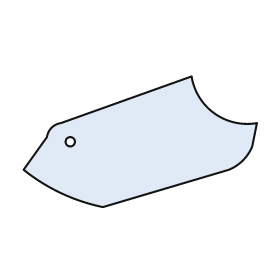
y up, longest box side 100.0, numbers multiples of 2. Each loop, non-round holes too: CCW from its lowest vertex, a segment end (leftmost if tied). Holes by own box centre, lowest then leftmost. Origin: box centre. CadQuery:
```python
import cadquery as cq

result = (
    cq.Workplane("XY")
    .moveTo(-16.0, -28.0)
    .lineTo(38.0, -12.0)
    .threePointArc((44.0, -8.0), (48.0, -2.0))
    .lineTo(50.0, 8.0)
    .threePointArc((32.0, 12.0), (22.0, 28.0))
    .lineTo(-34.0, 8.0)
    .threePointArc((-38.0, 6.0), (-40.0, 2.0))
    .lineTo(-50.0, -12.0)
    .threePointArc((-34.0, -22.0), (-16.0, -28.0))
    .close()
    .moveTo(-30.0, 0.0)
    .circle(2.0)
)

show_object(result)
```